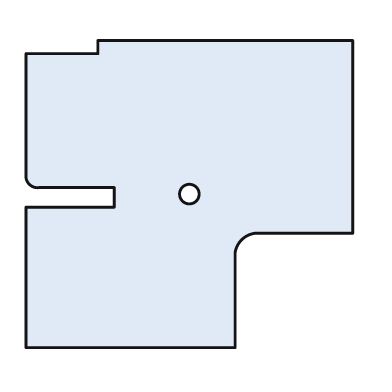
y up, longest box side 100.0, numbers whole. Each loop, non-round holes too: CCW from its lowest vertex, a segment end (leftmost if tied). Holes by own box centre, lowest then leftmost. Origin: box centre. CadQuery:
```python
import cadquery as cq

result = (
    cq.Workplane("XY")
    .moveTo(-50.0, -47.0)
    .lineTo(14.0, -47.0)
    .lineTo(14.0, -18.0)
    .threePointArc((16.0, -14.0), (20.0, -12.0))
    .lineTo(50.0, -12.0)
    .lineTo(50.0, 47.0)
    .lineTo(-28.0, 47.0)
    .lineTo(-28.0, 43.0)
    .lineTo(-50.0, 43.0)
    .lineTo(-50.0, 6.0)
    .threePointArc((-49.0, 3.0), (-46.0, 2.0))
    .lineTo(-23.0, 2.0)
    .lineTo(-23.0, -4.0)
    .lineTo(-50.0, -4.0)
    .close()
    .moveTo(0.0, 0.0)
    .circle(3.0)
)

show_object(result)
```